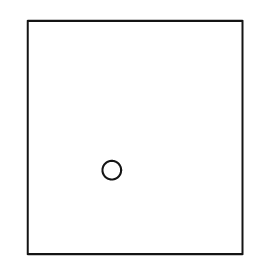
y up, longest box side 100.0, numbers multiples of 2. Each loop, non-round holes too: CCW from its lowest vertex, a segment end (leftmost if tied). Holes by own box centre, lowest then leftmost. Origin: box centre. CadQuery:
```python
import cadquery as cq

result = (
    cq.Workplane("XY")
    .moveTo(-46.0, -50.0)
    .lineTo(46.0, -50.0)
    .lineTo(46.0, 50.0)
    .lineTo(-46.0, 50.0)
    .close()
    .moveTo(-10.0, -14.0)
    .circle(4.0)
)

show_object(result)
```